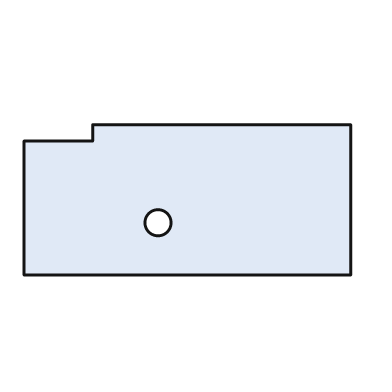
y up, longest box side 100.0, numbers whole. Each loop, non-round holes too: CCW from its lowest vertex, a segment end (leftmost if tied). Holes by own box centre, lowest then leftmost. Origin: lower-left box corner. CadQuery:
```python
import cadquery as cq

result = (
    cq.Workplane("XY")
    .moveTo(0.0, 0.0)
    .lineTo(100.0, 0.0)
    .lineTo(100.0, 46.0)
    .lineTo(21.0, 46.0)
    .lineTo(21.0, 41.0)
    .lineTo(0.0, 41.0)
    .close()
    .moveTo(41.0, 16.0)
    .circle(4.0)
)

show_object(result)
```